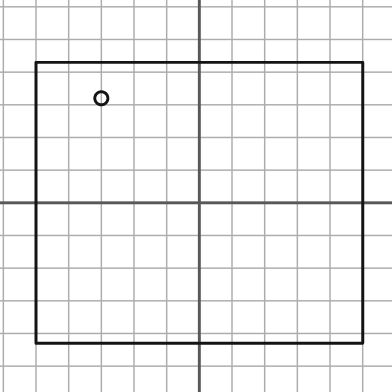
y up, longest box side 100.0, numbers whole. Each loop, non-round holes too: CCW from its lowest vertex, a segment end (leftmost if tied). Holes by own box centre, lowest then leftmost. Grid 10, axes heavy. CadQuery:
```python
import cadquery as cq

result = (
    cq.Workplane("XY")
    .moveTo(-50.0, -43.0)
    .lineTo(50.0, -43.0)
    .lineTo(50.0, 43.0)
    .lineTo(-50.0, 43.0)
    .close()
    .moveTo(-30.0, 32.0)
    .circle(2.0)
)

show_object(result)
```